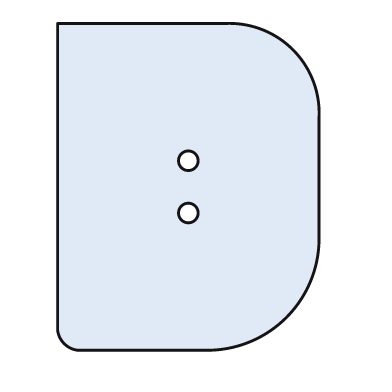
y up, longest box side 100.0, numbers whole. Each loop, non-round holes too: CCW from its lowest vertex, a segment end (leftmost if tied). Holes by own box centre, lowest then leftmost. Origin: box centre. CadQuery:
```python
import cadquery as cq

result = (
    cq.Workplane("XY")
    .moveTo(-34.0, -50.0)
    .lineTo(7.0, -50.0)
    .threePointArc((30.0, -40.0), (40.0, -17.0))
    .lineTo(40.0, 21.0)
    .threePointArc((32.0, 42.0), (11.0, 50.0))
    .lineTo(-40.0, 50.0)
    .lineTo(-40.0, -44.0)
    .threePointArc((-38.0, -48.0), (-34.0, -50.0))
    .close()
    .moveTo(0.0, -8.0)
    .circle(3.0)
    .moveTo(0.0, 8.0)
    .circle(3.0)
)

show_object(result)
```